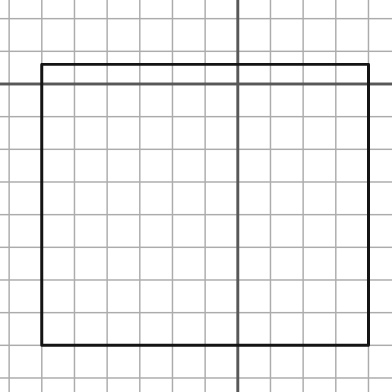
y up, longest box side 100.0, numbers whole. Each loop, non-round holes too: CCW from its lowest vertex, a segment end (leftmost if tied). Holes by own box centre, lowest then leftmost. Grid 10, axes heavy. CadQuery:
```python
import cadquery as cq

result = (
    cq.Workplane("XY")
    .moveTo(-60.0, -80.0)
    .lineTo(40.0, -80.0)
    .lineTo(40.0, 6.0)
    .lineTo(-60.0, 6.0)
    .close()
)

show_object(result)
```